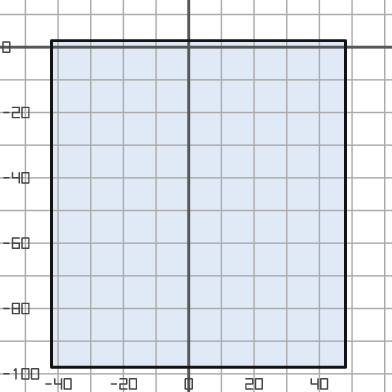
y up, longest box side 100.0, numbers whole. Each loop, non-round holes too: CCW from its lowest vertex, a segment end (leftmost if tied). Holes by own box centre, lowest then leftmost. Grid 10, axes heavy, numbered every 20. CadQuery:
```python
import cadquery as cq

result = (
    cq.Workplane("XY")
    .moveTo(-42.0, -98.0)
    .lineTo(48.0, -98.0)
    .lineTo(48.0, 2.0)
    .lineTo(-42.0, 2.0)
    .close()
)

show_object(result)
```